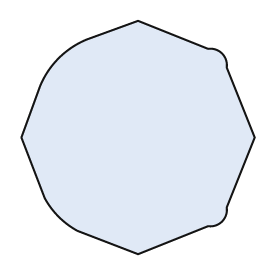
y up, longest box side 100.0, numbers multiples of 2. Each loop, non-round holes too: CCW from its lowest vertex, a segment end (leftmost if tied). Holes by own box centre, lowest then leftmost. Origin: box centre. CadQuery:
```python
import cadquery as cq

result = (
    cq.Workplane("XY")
    .moveTo(0.0, -50.0)
    .lineTo(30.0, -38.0)
    .threePointArc((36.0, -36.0), (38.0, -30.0))
    .lineTo(50.0, 0.0)
    .lineTo(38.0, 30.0)
    .threePointArc((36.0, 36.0), (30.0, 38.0))
    .lineTo(0.0, 50.0)
    .lineTo(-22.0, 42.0)
    .threePointArc((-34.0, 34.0), (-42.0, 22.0))
    .lineTo(-50.0, 0.0)
    .lineTo(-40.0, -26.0)
    .threePointArc((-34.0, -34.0), (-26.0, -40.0))
    .close()
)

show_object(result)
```